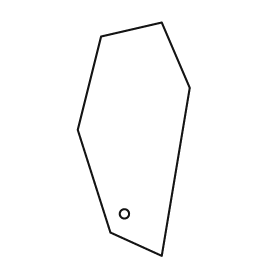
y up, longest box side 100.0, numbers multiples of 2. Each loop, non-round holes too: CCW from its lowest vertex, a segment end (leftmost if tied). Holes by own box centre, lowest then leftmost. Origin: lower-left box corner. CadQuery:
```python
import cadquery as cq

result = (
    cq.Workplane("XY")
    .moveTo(36.0, 0.0)
    .lineTo(48.0, 72.0)
    .lineTo(36.0, 100.0)
    .lineTo(10.0, 94.0)
    .lineTo(0.0, 54.0)
    .lineTo(14.0, 10.0)
    .close()
    .moveTo(20.0, 18.0)
    .circle(2.0)
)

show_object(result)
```